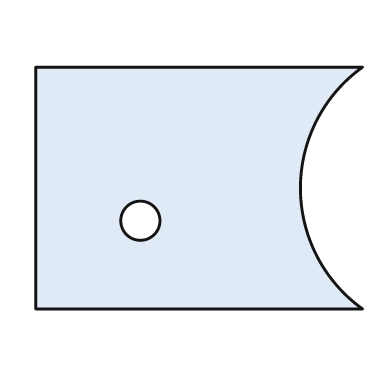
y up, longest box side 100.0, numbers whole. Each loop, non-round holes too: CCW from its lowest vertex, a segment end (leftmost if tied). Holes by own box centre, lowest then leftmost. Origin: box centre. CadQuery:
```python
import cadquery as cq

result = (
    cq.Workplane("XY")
    .moveTo(-50.0, -37.0)
    .lineTo(50.0, -37.0)
    .threePointArc((31.0, 0.0), (50.0, 37.0))
    .lineTo(-50.0, 37.0)
    .close()
    .moveTo(-18.0, -10.0)
    .circle(6.0)
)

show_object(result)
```